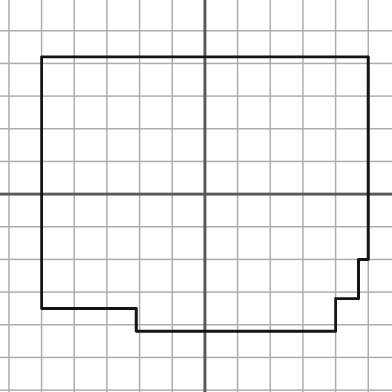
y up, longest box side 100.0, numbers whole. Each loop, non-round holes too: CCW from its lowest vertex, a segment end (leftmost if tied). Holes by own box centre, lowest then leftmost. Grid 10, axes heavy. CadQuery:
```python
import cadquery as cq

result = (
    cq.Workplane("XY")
    .moveTo(-21.0, -42.0)
    .lineTo(40.0, -42.0)
    .lineTo(40.0, -32.0)
    .lineTo(47.0, -32.0)
    .lineTo(47.0, -20.0)
    .lineTo(50.0, -20.0)
    .lineTo(50.0, 42.0)
    .lineTo(-50.0, 42.0)
    .lineTo(-50.0, -35.0)
    .lineTo(-21.0, -35.0)
    .close()
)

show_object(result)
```